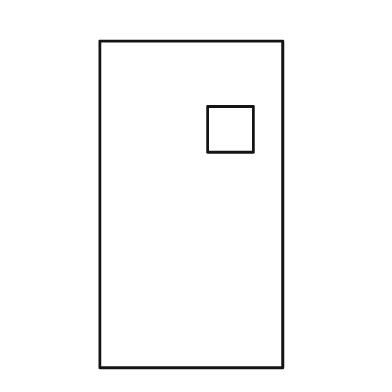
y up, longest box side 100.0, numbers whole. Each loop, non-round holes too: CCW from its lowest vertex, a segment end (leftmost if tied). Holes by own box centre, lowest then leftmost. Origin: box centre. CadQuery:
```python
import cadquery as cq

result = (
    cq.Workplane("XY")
    .moveTo(-28.0, -50.0)
    .lineTo(28.0, -50.0)
    .lineTo(28.0, 50.0)
    .lineTo(-28.0, 50.0)
    .close()
    .moveTo(5.0, 16.0)
    .lineTo(19.0, 16.0)
    .lineTo(19.0, 30.0)
    .lineTo(5.0, 30.0)
    .close()
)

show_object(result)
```